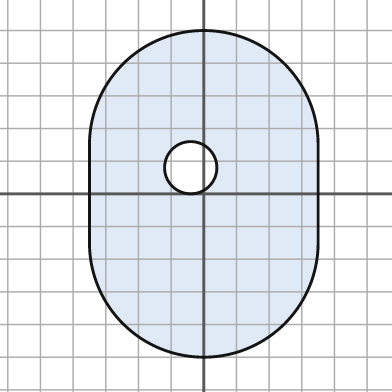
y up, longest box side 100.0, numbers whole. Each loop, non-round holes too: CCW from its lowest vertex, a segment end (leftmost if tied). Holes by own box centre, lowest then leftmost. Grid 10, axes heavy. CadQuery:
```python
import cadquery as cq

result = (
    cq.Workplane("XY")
    .moveTo(-35.0, -15.0)
    .threePointArc((0.0, -50.0), (35.0, -15.0))
    .lineTo(35.0, 15.0)
    .threePointArc((0.0, 50.0), (-35.0, 15.0))
    .close()
    .moveTo(-4.0, 8.0)
    .circle(8.0)
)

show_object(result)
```